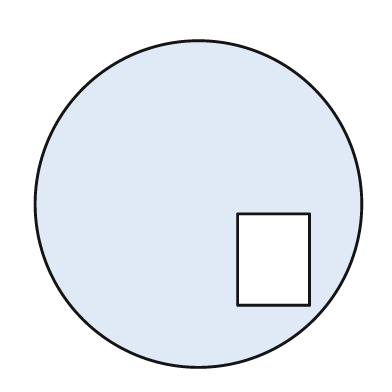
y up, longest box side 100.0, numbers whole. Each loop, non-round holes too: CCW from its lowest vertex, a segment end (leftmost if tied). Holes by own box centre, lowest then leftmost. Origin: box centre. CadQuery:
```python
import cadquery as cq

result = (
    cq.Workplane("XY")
    .moveTo(0.0, 0.0)
    .circle(50.0)
    .moveTo(12.0, -31.0)
    .lineTo(34.0, -31.0)
    .lineTo(34.0, -3.0)
    .lineTo(12.0, -3.0)
    .close()
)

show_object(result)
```